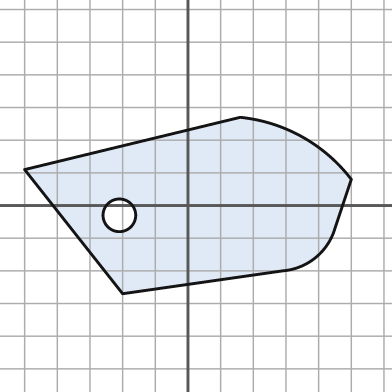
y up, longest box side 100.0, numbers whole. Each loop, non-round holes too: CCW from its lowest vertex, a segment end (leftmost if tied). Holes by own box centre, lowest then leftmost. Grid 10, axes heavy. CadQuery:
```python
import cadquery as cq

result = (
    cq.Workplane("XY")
    .moveTo(-20.0, -27.0)
    .lineTo(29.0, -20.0)
    .threePointArc((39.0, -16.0), (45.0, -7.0))
    .lineTo(50.0, 8.0)
    .threePointArc((35.0, 21.0), (16.0, 27.0))
    .lineTo(-50.0, 11.0)
    .close()
    .moveTo(-21.0, -3.0)
    .circle(5.0)
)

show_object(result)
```